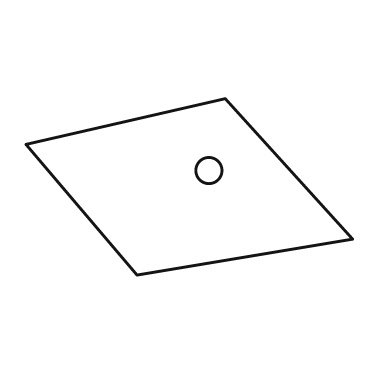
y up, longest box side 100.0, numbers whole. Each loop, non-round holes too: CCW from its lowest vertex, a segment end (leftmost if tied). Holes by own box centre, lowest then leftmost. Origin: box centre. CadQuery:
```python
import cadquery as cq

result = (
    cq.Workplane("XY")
    .moveTo(-16.0, -27.0)
    .lineTo(50.0, -16.0)
    .lineTo(11.0, 27.0)
    .lineTo(-50.0, 13.0)
    .close()
    .moveTo(6.0, 5.0)
    .circle(4.0)
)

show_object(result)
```